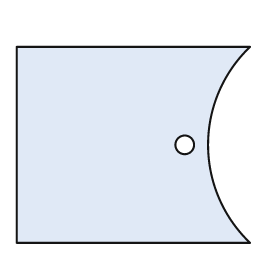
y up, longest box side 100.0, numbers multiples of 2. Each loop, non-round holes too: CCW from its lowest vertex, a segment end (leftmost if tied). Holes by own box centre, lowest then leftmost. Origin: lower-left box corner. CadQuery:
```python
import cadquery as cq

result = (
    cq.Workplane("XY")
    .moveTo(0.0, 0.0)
    .lineTo(100.0, 0.0)
    .threePointArc((82.0, 42.0), (100.0, 84.0))
    .lineTo(0.0, 84.0)
    .close()
    .moveTo(72.0, 42.0)
    .circle(4.0)
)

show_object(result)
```